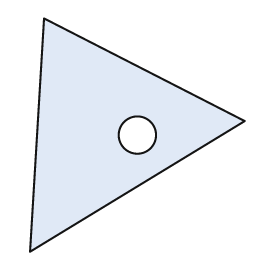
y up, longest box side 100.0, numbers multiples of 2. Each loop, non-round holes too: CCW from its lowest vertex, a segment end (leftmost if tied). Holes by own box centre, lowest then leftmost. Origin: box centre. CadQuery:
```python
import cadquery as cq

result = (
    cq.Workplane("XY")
    .moveTo(-46.0, -50.0)
    .lineTo(46.0, 6.0)
    .lineTo(-40.0, 50.0)
    .close()
    .moveTo(0.0, 0.0)
    .circle(8.0)
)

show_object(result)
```